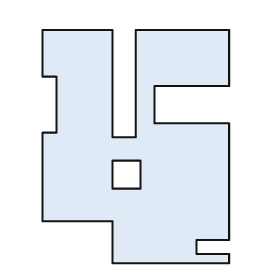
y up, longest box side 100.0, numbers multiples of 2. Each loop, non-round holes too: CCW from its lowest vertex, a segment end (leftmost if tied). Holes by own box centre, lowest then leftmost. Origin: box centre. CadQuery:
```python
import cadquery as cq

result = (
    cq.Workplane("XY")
    .moveTo(-10.0, -50.0)
    .lineTo(40.0, -50.0)
    .lineTo(40.0, -46.0)
    .lineTo(26.0, -46.0)
    .lineTo(26.0, -40.0)
    .lineTo(40.0, -40.0)
    .lineTo(40.0, 10.0)
    .lineTo(8.0, 10.0)
    .lineTo(8.0, 26.0)
    .lineTo(40.0, 26.0)
    .lineTo(40.0, 50.0)
    .lineTo(0.0, 50.0)
    .lineTo(0.0, 4.0)
    .lineTo(-10.0, 4.0)
    .lineTo(-10.0, 50.0)
    .lineTo(-40.0, 50.0)
    .lineTo(-40.0, 30.0)
    .lineTo(-34.0, 30.0)
    .lineTo(-34.0, 6.0)
    .lineTo(-40.0, 6.0)
    .lineTo(-40.0, -32.0)
    .lineTo(-10.0, -32.0)
    .close()
    .moveTo(-10.0, -18.0)
    .lineTo(2.0, -18.0)
    .lineTo(2.0, -6.0)
    .lineTo(-10.0, -6.0)
    .close()
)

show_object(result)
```